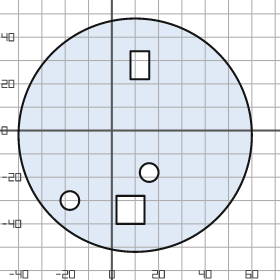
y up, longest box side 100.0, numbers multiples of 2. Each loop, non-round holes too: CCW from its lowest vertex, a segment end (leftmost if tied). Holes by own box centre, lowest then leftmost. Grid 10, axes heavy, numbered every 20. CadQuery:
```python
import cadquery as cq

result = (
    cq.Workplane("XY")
    .moveTo(10.0, -2.0)
    .circle(50.0)
    .moveTo(2.0, -40.0)
    .lineTo(14.0, -40.0)
    .lineTo(14.0, -28.0)
    .lineTo(2.0, -28.0)
    .close()
    .moveTo(-18.0, -30.0)
    .circle(4.0)
    .moveTo(16.0, -18.0)
    .circle(4.0)
    .moveTo(8.0, 22.0)
    .lineTo(16.0, 22.0)
    .lineTo(16.0, 34.0)
    .lineTo(8.0, 34.0)
    .close()
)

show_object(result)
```